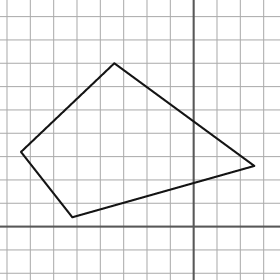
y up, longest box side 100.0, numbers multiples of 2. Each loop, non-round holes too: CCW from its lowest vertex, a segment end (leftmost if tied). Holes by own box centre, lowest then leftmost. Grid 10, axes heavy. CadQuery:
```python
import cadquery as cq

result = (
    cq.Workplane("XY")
    .moveTo(-52.0, 4.0)
    .lineTo(26.0, 26.0)
    .lineTo(-34.0, 70.0)
    .lineTo(-74.0, 32.0)
    .close()
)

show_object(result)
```